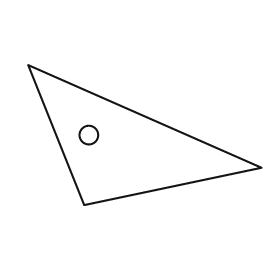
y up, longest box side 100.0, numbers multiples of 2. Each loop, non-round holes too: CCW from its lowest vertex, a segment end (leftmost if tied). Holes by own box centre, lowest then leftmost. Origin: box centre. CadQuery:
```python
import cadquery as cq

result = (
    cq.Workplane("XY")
    .moveTo(-26.0, -30.0)
    .lineTo(50.0, -14.0)
    .lineTo(-50.0, 30.0)
    .close()
    .moveTo(-24.0, 0.0)
    .circle(4.0)
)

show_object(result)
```